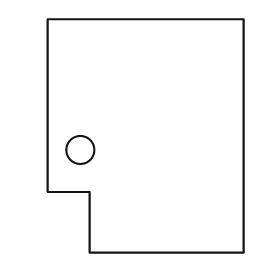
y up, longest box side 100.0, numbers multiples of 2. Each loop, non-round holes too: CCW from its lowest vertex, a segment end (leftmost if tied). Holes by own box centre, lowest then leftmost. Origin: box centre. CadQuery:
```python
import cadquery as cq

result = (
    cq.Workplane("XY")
    .moveTo(-24.0, -50.0)
    .lineTo(42.0, -50.0)
    .lineTo(42.0, 50.0)
    .lineTo(-42.0, 50.0)
    .lineTo(-42.0, -24.0)
    .lineTo(-24.0, -24.0)
    .close()
    .moveTo(-28.0, -6.0)
    .circle(6.0)
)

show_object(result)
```